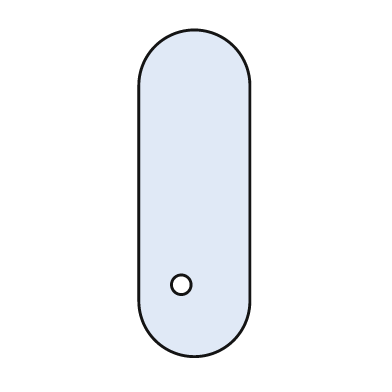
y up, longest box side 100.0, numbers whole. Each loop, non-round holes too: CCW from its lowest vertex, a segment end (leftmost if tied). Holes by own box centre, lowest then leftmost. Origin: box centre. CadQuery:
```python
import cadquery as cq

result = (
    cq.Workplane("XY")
    .moveTo(-17.0, -33.0)
    .threePointArc((0.0, -50.0), (17.0, -33.0))
    .lineTo(17.0, 33.0)
    .threePointArc((0.0, 50.0), (-17.0, 33.0))
    .close()
    .moveTo(-4.0, -28.0)
    .circle(3.0)
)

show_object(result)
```